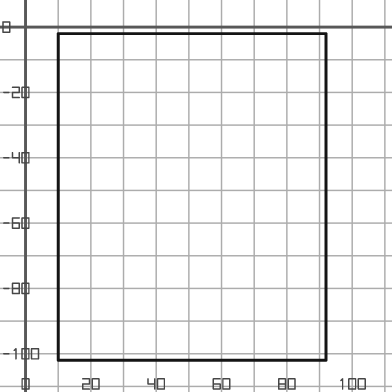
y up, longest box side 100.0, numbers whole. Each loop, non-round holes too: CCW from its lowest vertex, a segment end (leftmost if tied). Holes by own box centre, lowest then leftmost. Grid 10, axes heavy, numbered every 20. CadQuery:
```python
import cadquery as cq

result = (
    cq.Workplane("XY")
    .moveTo(10.0, -102.0)
    .lineTo(92.0, -102.0)
    .lineTo(92.0, -2.0)
    .lineTo(10.0, -2.0)
    .close()
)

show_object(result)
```